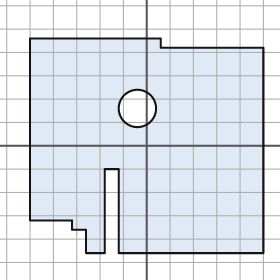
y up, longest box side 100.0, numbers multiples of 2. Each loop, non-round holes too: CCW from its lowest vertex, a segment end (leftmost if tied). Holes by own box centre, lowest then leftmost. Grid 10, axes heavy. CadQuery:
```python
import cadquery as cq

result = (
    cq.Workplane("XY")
    .moveTo(-26.0, -46.0)
    .lineTo(-18.0, -46.0)
    .lineTo(-18.0, -10.0)
    .lineTo(-12.0, -10.0)
    .lineTo(-12.0, -46.0)
    .lineTo(50.0, -46.0)
    .lineTo(50.0, 42.0)
    .lineTo(6.0, 42.0)
    .lineTo(6.0, 46.0)
    .lineTo(-50.0, 46.0)
    .lineTo(-50.0, -32.0)
    .lineTo(-32.0, -32.0)
    .lineTo(-32.0, -36.0)
    .lineTo(-26.0, -36.0)
    .close()
    .moveTo(-4.0, 16.0)
    .circle(8.0)
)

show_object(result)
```